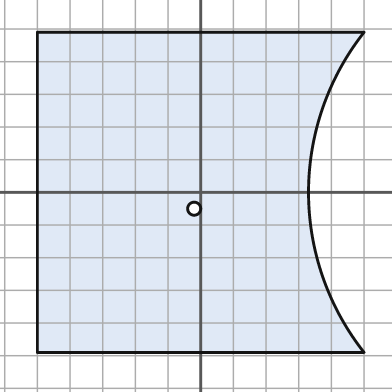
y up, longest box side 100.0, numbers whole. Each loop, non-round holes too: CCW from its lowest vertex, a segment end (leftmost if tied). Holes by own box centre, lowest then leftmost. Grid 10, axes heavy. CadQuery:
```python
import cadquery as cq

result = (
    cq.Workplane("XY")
    .moveTo(-50.0, -49.0)
    .lineTo(50.0, -49.0)
    .threePointArc((33.0, 0.0), (50.0, 49.0))
    .lineTo(-50.0, 49.0)
    .close()
    .moveTo(-2.0, -5.0)
    .circle(2.0)
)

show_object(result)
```